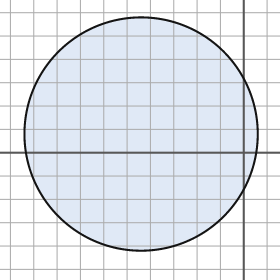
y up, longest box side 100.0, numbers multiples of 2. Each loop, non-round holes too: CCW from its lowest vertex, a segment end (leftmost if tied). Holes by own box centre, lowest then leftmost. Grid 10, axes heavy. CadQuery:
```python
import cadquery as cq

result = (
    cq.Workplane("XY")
    .moveTo(-44.0, 8.0)
    .circle(50.0)
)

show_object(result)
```